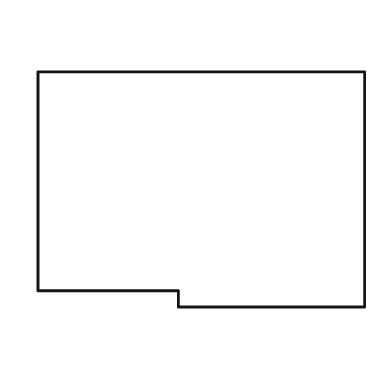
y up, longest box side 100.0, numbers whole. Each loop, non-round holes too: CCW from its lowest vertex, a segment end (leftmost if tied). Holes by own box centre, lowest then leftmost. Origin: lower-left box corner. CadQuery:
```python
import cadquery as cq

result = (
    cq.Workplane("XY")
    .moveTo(43.0, 0.0)
    .lineTo(100.0, 0.0)
    .lineTo(100.0, 72.0)
    .lineTo(0.0, 72.0)
    .lineTo(0.0, 5.0)
    .lineTo(43.0, 5.0)
    .close()
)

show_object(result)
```